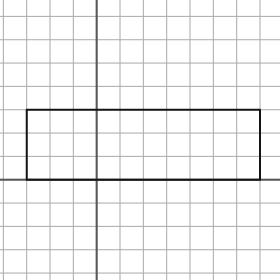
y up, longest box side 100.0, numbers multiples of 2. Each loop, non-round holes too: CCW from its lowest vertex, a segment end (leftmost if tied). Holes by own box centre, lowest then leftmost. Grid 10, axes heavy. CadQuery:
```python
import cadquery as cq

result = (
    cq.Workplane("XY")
    .moveTo(-30.0, 0.0)
    .lineTo(70.0, 0.0)
    .lineTo(70.0, 30.0)
    .lineTo(-30.0, 30.0)
    .close()
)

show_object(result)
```